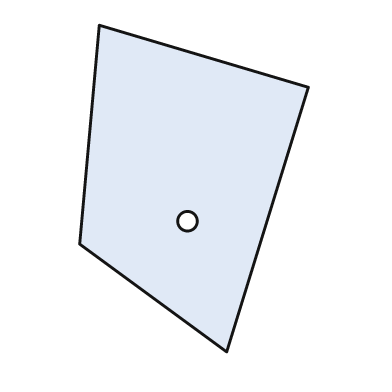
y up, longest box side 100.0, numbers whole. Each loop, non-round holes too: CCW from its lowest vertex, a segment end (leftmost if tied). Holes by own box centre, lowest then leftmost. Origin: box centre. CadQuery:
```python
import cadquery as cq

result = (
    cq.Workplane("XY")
    .moveTo(10.0, -50.0)
    .lineTo(35.0, 31.0)
    .lineTo(-29.0, 50.0)
    .lineTo(-35.0, -17.0)
    .close()
    .moveTo(-2.0, -10.0)
    .circle(3.0)
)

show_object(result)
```